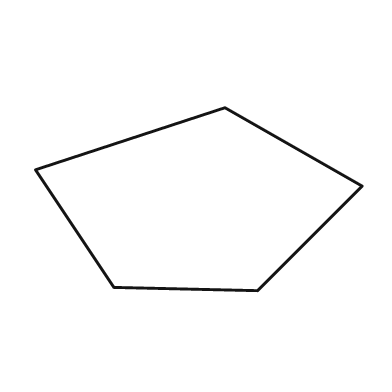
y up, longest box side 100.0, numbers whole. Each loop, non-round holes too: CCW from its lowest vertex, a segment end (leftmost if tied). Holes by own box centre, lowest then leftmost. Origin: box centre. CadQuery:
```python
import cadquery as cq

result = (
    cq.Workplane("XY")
    .moveTo(18.0, -28.0)
    .lineTo(50.0, 4.0)
    .lineTo(8.0, 28.0)
    .lineTo(-50.0, 9.0)
    .lineTo(-26.0, -27.0)
    .close()
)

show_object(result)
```